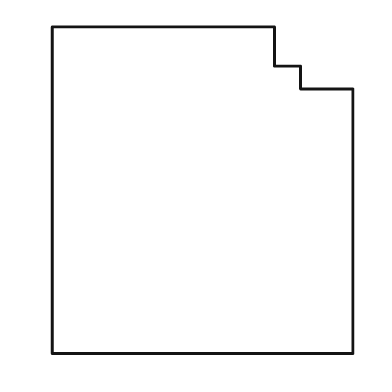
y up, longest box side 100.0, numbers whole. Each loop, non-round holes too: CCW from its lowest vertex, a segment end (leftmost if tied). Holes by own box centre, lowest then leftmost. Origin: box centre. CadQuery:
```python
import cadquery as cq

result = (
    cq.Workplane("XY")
    .moveTo(-46.0, -50.0)
    .lineTo(46.0, -50.0)
    .lineTo(46.0, 31.0)
    .lineTo(30.0, 31.0)
    .lineTo(30.0, 38.0)
    .lineTo(22.0, 38.0)
    .lineTo(22.0, 50.0)
    .lineTo(-46.0, 50.0)
    .close()
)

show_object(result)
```